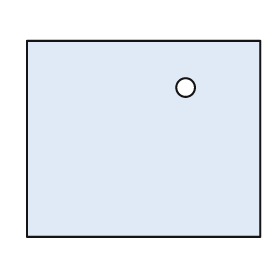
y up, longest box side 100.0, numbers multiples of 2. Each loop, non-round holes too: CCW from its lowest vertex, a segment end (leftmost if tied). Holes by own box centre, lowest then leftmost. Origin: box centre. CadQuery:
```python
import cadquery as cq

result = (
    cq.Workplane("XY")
    .moveTo(-50.0, -42.0)
    .lineTo(50.0, -42.0)
    .lineTo(50.0, 42.0)
    .lineTo(-50.0, 42.0)
    .close()
    .moveTo(18.0, 22.0)
    .circle(4.0)
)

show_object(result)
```